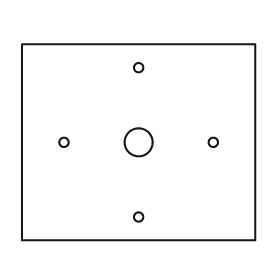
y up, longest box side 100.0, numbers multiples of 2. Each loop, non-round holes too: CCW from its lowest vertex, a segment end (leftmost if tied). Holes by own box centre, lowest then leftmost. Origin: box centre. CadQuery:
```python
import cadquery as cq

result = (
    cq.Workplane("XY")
    .moveTo(-50.0, -42.0)
    .lineTo(50.0, -42.0)
    .lineTo(50.0, 42.0)
    .lineTo(-50.0, 42.0)
    .close()
    .moveTo(0.0, -32.0)
    .circle(2.0)
    .moveTo(-32.0, 0.0)
    .circle(2.0)
    .moveTo(0.0, 0.0)
    .circle(6.0)
    .moveTo(32.0, 0.0)
    .circle(2.0)
    .moveTo(0.0, 32.0)
    .circle(2.0)
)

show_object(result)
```